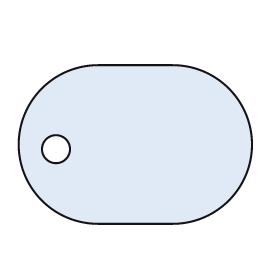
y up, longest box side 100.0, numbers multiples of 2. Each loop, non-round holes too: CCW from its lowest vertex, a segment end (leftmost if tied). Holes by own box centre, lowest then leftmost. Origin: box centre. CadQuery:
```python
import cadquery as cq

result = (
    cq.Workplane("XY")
    .moveTo(-16.0, -34.0)
    .lineTo(16.0, -34.0)
    .threePointArc((50.0, 0.0), (16.0, 34.0))
    .lineTo(-16.0, 34.0)
    .threePointArc((-50.0, 0.0), (-16.0, -34.0))
    .close()
    .moveTo(-34.0, -2.0)
    .circle(6.0)
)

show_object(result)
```